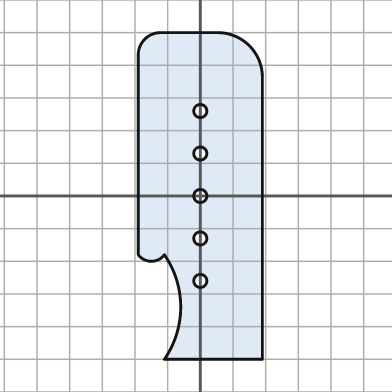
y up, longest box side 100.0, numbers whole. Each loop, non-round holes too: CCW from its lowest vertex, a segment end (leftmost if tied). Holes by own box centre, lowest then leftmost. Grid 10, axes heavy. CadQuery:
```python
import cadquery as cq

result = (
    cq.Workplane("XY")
    .moveTo(-11.0, -50.0)
    .lineTo(19.0, -50.0)
    .lineTo(19.0, 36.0)
    .threePointArc((15.0, 46.0), (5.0, 50.0))
    .lineTo(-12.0, 50.0)
    .threePointArc((-17.0, 48.0), (-19.0, 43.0))
    .lineTo(-19.0, -18.0)
    .threePointArc((-15.0, -20.0), (-11.0, -18.0))
    .threePointArc((-6.0, -34.0), (-11.0, -50.0))
    .close()
    .moveTo(0.0, -26.0)
    .circle(2.0)
    .moveTo(0.0, -13.0)
    .circle(2.0)
    .moveTo(0.0, 0.0)
    .circle(2.0)
    .moveTo(0.0, 13.0)
    .circle(2.0)
    .moveTo(0.0, 26.0)
    .circle(2.0)
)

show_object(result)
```